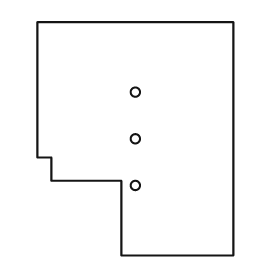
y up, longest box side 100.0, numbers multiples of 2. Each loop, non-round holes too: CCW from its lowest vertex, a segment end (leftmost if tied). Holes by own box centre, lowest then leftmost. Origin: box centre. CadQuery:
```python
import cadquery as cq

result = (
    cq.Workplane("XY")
    .moveTo(-6.0, -50.0)
    .lineTo(42.0, -50.0)
    .lineTo(42.0, 50.0)
    .lineTo(-42.0, 50.0)
    .lineTo(-42.0, -8.0)
    .lineTo(-36.0, -8.0)
    .lineTo(-36.0, -18.0)
    .lineTo(-6.0, -18.0)
    .close()
    .moveTo(0.0, -20.0)
    .circle(2.0)
    .moveTo(0.0, 0.0)
    .circle(2.0)
    .moveTo(0.0, 20.0)
    .circle(2.0)
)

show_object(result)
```